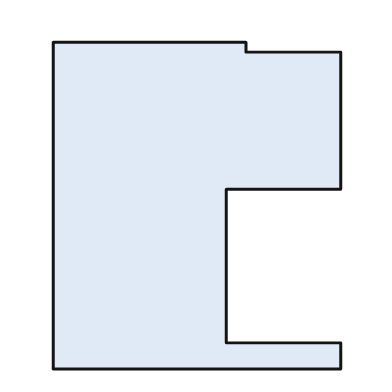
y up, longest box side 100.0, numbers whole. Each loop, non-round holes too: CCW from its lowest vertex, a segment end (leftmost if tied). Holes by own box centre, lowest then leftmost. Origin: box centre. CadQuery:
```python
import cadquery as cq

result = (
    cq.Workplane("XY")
    .moveTo(-44.0, -50.0)
    .lineTo(44.0, -50.0)
    .lineTo(44.0, -42.0)
    .lineTo(9.0, -42.0)
    .lineTo(9.0, 5.0)
    .lineTo(44.0, 5.0)
    .lineTo(44.0, 47.0)
    .lineTo(15.0, 47.0)
    .lineTo(15.0, 50.0)
    .lineTo(-44.0, 50.0)
    .close()
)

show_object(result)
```